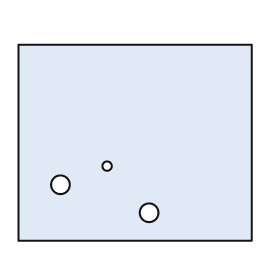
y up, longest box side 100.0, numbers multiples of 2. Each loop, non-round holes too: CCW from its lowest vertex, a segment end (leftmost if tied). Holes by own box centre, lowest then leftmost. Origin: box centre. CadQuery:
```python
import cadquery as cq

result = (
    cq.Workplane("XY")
    .moveTo(-50.0, -42.0)
    .lineTo(50.0, -42.0)
    .lineTo(50.0, 42.0)
    .lineTo(-50.0, 42.0)
    .close()
    .moveTo(6.0, -30.0)
    .circle(4.0)
    .moveTo(-32.0, -18.0)
    .circle(4.0)
    .moveTo(-12.0, -10.0)
    .circle(2.0)
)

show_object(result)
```